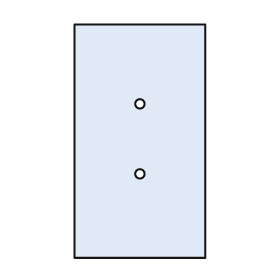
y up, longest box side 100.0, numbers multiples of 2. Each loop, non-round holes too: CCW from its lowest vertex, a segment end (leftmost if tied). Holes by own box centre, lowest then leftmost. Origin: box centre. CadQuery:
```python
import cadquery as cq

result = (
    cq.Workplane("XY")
    .moveTo(-28.0, -50.0)
    .lineTo(28.0, -50.0)
    .lineTo(28.0, 50.0)
    .lineTo(-28.0, 50.0)
    .close()
    .moveTo(0.0, -14.0)
    .circle(2.0)
    .moveTo(0.0, 16.0)
    .circle(2.0)
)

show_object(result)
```